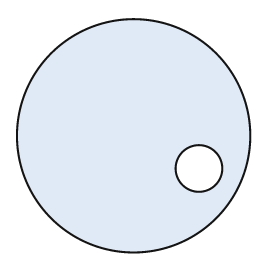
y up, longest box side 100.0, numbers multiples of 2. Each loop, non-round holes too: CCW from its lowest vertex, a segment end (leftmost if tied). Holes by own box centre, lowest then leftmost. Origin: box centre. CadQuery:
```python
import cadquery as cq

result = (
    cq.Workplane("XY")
    .moveTo(0.0, 0.0)
    .circle(50.0)
    .moveTo(28.0, -14.0)
    .circle(10.0)
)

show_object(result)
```